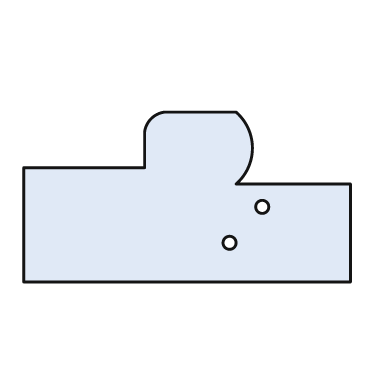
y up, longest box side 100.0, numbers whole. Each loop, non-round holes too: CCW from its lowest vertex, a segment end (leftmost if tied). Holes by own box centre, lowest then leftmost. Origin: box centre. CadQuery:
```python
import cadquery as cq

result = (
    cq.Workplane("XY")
    .moveTo(-50.0, -26.0)
    .lineTo(50.0, -26.0)
    .lineTo(50.0, 4.0)
    .lineTo(15.0, 4.0)
    .threePointArc((20.0, 15.0), (15.0, 26.0))
    .lineTo(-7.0, 26.0)
    .threePointArc((-11.0, 24.0), (-13.0, 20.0))
    .lineTo(-13.0, 9.0)
    .lineTo(-50.0, 9.0)
    .close()
    .moveTo(13.0, -14.0)
    .circle(2.0)
    .moveTo(23.0, -3.0)
    .circle(2.0)
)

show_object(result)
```